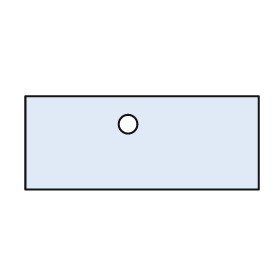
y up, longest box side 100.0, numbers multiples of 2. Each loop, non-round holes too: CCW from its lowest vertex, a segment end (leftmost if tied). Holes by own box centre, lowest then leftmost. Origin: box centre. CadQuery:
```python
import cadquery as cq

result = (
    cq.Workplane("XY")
    .moveTo(-50.0, -20.0)
    .lineTo(50.0, -20.0)
    .lineTo(50.0, 20.0)
    .lineTo(-50.0, 20.0)
    .close()
    .moveTo(-6.0, 8.0)
    .circle(4.0)
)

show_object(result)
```